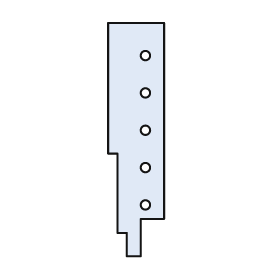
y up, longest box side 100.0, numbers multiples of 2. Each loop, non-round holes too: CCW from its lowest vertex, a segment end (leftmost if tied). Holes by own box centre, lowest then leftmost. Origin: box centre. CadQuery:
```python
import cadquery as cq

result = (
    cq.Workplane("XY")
    .moveTo(-4.0, -50.0)
    .lineTo(2.0, -50.0)
    .lineTo(2.0, -34.0)
    .lineTo(12.0, -34.0)
    .lineTo(12.0, 50.0)
    .lineTo(-12.0, 50.0)
    .lineTo(-12.0, -6.0)
    .lineTo(-8.0, -6.0)
    .lineTo(-8.0, -40.0)
    .lineTo(-4.0, -40.0)
    .close()
    .moveTo(4.0, -28.0)
    .circle(2.0)
    .moveTo(4.0, -12.0)
    .circle(2.0)
    .moveTo(4.0, 4.0)
    .circle(2.0)
    .moveTo(4.0, 20.0)
    .circle(2.0)
    .moveTo(4.0, 36.0)
    .circle(2.0)
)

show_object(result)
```